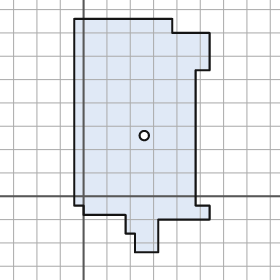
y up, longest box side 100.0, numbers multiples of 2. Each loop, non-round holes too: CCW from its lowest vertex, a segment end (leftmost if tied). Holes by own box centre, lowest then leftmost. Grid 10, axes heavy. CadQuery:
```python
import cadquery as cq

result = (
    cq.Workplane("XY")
    .moveTo(22.0, -24.0)
    .lineTo(32.0, -24.0)
    .lineTo(32.0, -10.0)
    .lineTo(54.0, -10.0)
    .lineTo(54.0, -4.0)
    .lineTo(48.0, -4.0)
    .lineTo(48.0, 54.0)
    .lineTo(54.0, 54.0)
    .lineTo(54.0, 70.0)
    .lineTo(38.0, 70.0)
    .lineTo(38.0, 76.0)
    .lineTo(-4.0, 76.0)
    .lineTo(-4.0, -4.0)
    .lineTo(0.0, -4.0)
    .lineTo(0.0, -8.0)
    .lineTo(18.0, -8.0)
    .lineTo(18.0, -16.0)
    .lineTo(22.0, -16.0)
    .close()
    .moveTo(26.0, 26.0)
    .circle(2.0)
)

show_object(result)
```